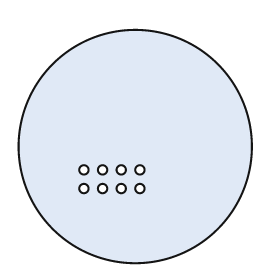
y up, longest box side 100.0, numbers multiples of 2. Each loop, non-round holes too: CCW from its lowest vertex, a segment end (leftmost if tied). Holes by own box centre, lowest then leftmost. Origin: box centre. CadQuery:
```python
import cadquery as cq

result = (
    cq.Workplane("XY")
    .moveTo(0.0, 0.0)
    .circle(50.0)
    .moveTo(-22.0, -18.0)
    .circle(2.0)
    .moveTo(-14.0, -18.0)
    .circle(2.0)
    .moveTo(-6.0, -18.0)
    .circle(2.0)
    .moveTo(2.0, -18.0)
    .circle(2.0)
    .moveTo(-22.0, -10.0)
    .circle(2.0)
    .moveTo(-14.0, -10.0)
    .circle(2.0)
    .moveTo(-6.0, -10.0)
    .circle(2.0)
    .moveTo(2.0, -10.0)
    .circle(2.0)
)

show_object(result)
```